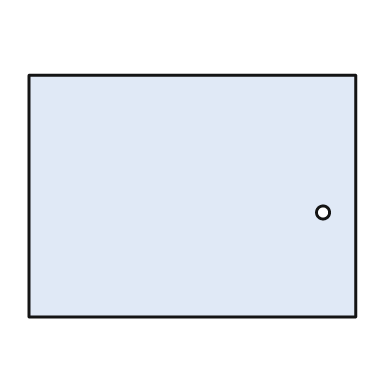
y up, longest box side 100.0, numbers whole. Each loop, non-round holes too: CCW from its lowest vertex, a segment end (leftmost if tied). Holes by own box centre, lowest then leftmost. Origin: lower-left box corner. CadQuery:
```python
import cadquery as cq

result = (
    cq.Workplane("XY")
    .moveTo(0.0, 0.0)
    .lineTo(100.0, 0.0)
    .lineTo(100.0, 74.0)
    .lineTo(0.0, 74.0)
    .close()
    .moveTo(90.0, 32.0)
    .circle(2.0)
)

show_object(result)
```